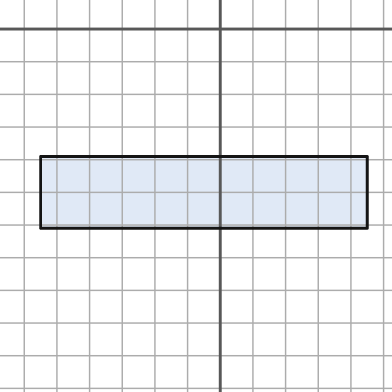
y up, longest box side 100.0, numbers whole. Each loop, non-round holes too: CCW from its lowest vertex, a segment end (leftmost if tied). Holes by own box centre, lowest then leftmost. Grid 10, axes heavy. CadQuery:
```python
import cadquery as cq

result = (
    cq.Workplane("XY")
    .moveTo(-55.0, -61.0)
    .lineTo(45.0, -61.0)
    .lineTo(45.0, -39.0)
    .lineTo(-55.0, -39.0)
    .close()
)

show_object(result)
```